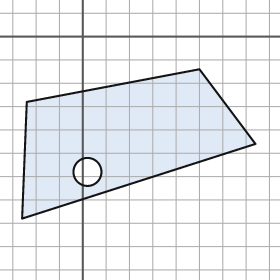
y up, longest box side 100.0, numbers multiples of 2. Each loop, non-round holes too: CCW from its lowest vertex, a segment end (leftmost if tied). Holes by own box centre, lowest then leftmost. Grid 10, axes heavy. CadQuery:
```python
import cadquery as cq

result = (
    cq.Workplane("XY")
    .moveTo(-26.0, -78.0)
    .lineTo(74.0, -46.0)
    .lineTo(50.0, -14.0)
    .lineTo(-24.0, -28.0)
    .close()
    .moveTo(2.0, -58.0)
    .circle(6.0)
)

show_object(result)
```